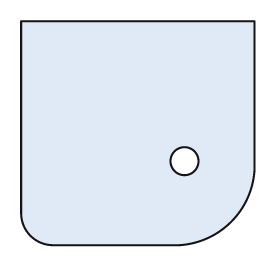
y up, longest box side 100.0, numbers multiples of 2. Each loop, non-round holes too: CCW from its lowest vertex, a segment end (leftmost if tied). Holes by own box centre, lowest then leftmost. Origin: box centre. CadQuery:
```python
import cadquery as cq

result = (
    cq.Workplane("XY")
    .moveTo(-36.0, -48.0)
    .lineTo(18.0, -48.0)
    .threePointArc((40.0, -38.0), (50.0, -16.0))
    .lineTo(50.0, 48.0)
    .lineTo(-50.0, 48.0)
    .lineTo(-50.0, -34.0)
    .threePointArc((-46.0, -44.0), (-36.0, -48.0))
    .close()
    .moveTo(20.0, -12.0)
    .circle(6.0)
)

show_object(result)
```